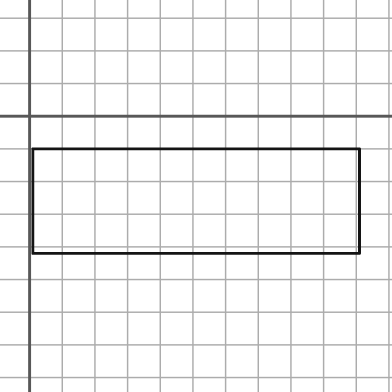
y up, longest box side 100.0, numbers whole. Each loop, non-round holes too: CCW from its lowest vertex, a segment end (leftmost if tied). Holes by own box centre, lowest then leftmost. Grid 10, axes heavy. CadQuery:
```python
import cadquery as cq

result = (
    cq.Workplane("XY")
    .moveTo(1.0, -42.0)
    .lineTo(101.0, -42.0)
    .lineTo(101.0, -10.0)
    .lineTo(1.0, -10.0)
    .close()
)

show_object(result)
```